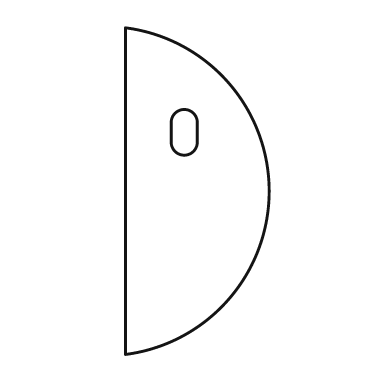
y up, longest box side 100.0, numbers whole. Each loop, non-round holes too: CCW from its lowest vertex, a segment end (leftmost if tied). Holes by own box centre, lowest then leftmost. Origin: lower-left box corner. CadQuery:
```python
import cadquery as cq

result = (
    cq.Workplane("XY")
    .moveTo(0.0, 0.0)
    .threePointArc((44.0, 50.0), (0.0, 100.0))
    .close()
    .moveTo(14.0, 65.0)
    .threePointArc((18.0, 61.0), (22.0, 65.0))
    .lineTo(22.0, 71.0)
    .threePointArc((18.0, 75.0), (14.0, 71.0))
    .close()
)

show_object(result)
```